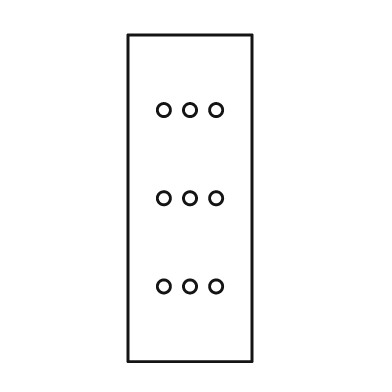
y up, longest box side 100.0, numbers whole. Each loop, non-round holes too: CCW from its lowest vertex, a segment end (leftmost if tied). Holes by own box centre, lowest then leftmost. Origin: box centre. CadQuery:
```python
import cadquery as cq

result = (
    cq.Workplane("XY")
    .moveTo(-19.0, -50.0)
    .lineTo(19.0, -50.0)
    .lineTo(19.0, 50.0)
    .lineTo(-19.0, 50.0)
    .close()
    .moveTo(-8.0, -27.0)
    .circle(2.0)
    .moveTo(0.0, -27.0)
    .circle(2.0)
    .moveTo(8.0, -27.0)
    .circle(2.0)
    .moveTo(-8.0, 0.0)
    .circle(2.0)
    .moveTo(0.0, 0.0)
    .circle(2.0)
    .moveTo(8.0, 0.0)
    .circle(2.0)
    .moveTo(-8.0, 27.0)
    .circle(2.0)
    .moveTo(0.0, 27.0)
    .circle(2.0)
    .moveTo(8.0, 27.0)
    .circle(2.0)
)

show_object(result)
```